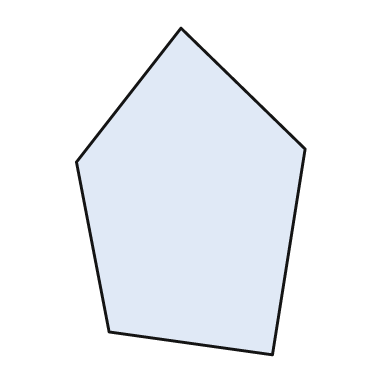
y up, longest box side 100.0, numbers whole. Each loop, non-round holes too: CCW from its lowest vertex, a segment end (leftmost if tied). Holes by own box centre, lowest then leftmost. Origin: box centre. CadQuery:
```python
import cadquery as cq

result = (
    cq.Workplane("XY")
    .moveTo(25.0, -50.0)
    .lineTo(35.0, 13.0)
    .lineTo(-3.0, 50.0)
    .lineTo(-35.0, 9.0)
    .lineTo(-25.0, -43.0)
    .close()
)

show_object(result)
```